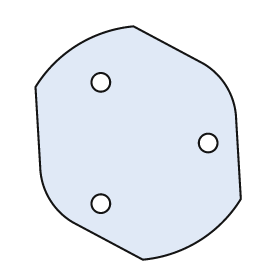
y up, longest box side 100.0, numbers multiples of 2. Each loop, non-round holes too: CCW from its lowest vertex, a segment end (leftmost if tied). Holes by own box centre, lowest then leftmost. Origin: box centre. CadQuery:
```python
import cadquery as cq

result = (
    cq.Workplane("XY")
    .moveTo(2.0, -50.0)
    .threePointArc((26.0, -42.0), (44.0, -24.0))
    .lineTo(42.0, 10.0)
    .threePointArc((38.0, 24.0), (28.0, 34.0))
    .lineTo(-2.0, 50.0)
    .threePointArc((-26.0, 42.0), (-44.0, 24.0))
    .lineTo(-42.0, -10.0)
    .threePointArc((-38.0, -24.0), (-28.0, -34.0))
    .close()
    .moveTo(-16.0, -26.0)
    .circle(4.0)
    .moveTo(30.0, 0.0)
    .circle(4.0)
    .moveTo(-16.0, 26.0)
    .circle(4.0)
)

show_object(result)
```